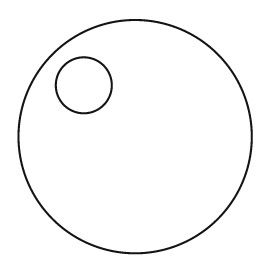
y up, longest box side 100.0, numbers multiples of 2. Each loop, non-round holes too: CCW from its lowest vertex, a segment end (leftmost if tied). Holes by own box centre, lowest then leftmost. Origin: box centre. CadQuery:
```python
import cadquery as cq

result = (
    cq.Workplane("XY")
    .moveTo(0.0, 0.0)
    .circle(50.0)
    .moveTo(-22.0, 22.0)
    .circle(12.0)
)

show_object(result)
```